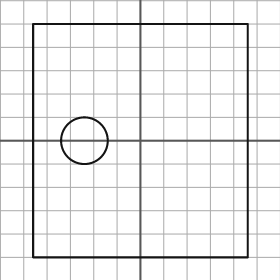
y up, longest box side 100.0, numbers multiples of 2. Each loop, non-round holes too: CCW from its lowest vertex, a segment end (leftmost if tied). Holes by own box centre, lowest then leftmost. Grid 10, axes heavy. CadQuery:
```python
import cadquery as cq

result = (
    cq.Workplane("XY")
    .moveTo(-46.0, -50.0)
    .lineTo(46.0, -50.0)
    .lineTo(46.0, 50.0)
    .lineTo(-46.0, 50.0)
    .close()
    .moveTo(-24.0, 0.0)
    .circle(10.0)
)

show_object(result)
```